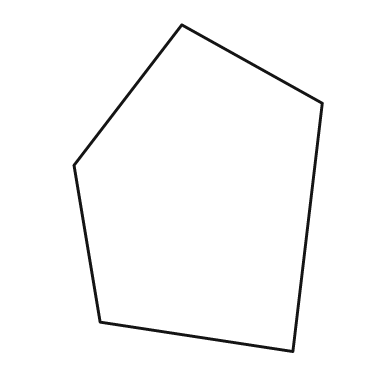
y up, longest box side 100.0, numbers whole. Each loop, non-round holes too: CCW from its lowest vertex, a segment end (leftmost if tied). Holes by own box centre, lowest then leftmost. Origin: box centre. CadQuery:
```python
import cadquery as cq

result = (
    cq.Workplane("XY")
    .moveTo(29.0, -50.0)
    .lineTo(38.0, 26.0)
    .lineTo(-5.0, 50.0)
    .lineTo(-38.0, 7.0)
    .lineTo(-30.0, -41.0)
    .close()
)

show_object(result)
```